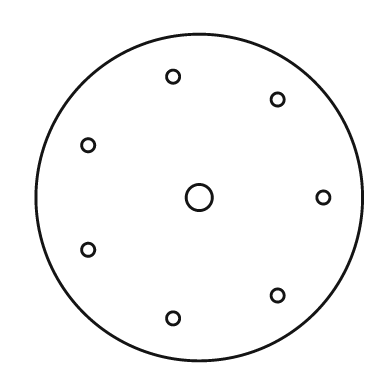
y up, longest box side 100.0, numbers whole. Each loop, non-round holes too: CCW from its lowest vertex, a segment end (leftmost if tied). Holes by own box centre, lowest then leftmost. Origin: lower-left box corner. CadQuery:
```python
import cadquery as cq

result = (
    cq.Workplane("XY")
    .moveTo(50.0, 50.0)
    .circle(50.0)
    .moveTo(42.0, 13.0)
    .circle(2.0)
    .moveTo(74.0, 20.0)
    .circle(2.0)
    .moveTo(16.0, 34.0)
    .circle(2.0)
    .moveTo(50.0, 50.0)
    .circle(4.0)
    .moveTo(88.0, 50.0)
    .circle(2.0)
    .moveTo(16.0, 66.0)
    .circle(2.0)
    .moveTo(74.0, 80.0)
    .circle(2.0)
    .moveTo(42.0, 87.0)
    .circle(2.0)
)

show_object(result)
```